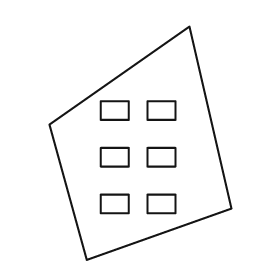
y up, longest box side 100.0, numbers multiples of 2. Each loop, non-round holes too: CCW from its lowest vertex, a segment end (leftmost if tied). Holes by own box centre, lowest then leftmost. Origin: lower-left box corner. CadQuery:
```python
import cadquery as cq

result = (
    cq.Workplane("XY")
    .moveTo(16.0, 0.0)
    .lineTo(78.0, 22.0)
    .lineTo(60.0, 100.0)
    .lineTo(0.0, 58.0)
    .close()
    .moveTo(22.0, 20.0)
    .lineTo(34.0, 20.0)
    .lineTo(34.0, 28.0)
    .lineTo(22.0, 28.0)
    .close()
    .moveTo(42.0, 20.0)
    .lineTo(54.0, 20.0)
    .lineTo(54.0, 28.0)
    .lineTo(42.0, 28.0)
    .close()
    .moveTo(22.0, 40.0)
    .lineTo(34.0, 40.0)
    .lineTo(34.0, 48.0)
    .lineTo(22.0, 48.0)
    .close()
    .moveTo(42.0, 40.0)
    .lineTo(54.0, 40.0)
    .lineTo(54.0, 48.0)
    .lineTo(42.0, 48.0)
    .close()
    .moveTo(22.0, 60.0)
    .lineTo(34.0, 60.0)
    .lineTo(34.0, 68.0)
    .lineTo(22.0, 68.0)
    .close()
    .moveTo(42.0, 60.0)
    .lineTo(54.0, 60.0)
    .lineTo(54.0, 68.0)
    .lineTo(42.0, 68.0)
    .close()
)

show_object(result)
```